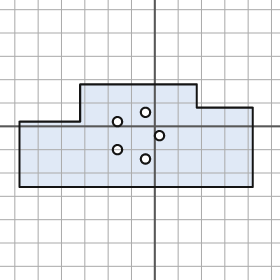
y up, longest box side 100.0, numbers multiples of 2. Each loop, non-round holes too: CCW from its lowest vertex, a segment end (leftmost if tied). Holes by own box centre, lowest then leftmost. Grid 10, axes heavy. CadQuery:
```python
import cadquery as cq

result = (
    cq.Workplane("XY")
    .moveTo(-58.0, -26.0)
    .lineTo(42.0, -26.0)
    .lineTo(42.0, 8.0)
    .lineTo(18.0, 8.0)
    .lineTo(18.0, 18.0)
    .lineTo(-32.0, 18.0)
    .lineTo(-32.0, 2.0)
    .lineTo(-58.0, 2.0)
    .close()
    .moveTo(-4.0, -14.0)
    .circle(2.0)
    .moveTo(-16.0, -10.0)
    .circle(2.0)
    .moveTo(2.0, -4.0)
    .circle(2.0)
    .moveTo(-16.0, 2.0)
    .circle(2.0)
    .moveTo(-4.0, 6.0)
    .circle(2.0)
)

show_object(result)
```